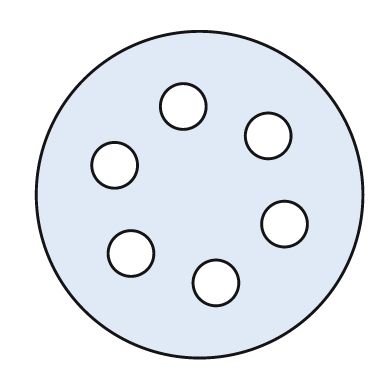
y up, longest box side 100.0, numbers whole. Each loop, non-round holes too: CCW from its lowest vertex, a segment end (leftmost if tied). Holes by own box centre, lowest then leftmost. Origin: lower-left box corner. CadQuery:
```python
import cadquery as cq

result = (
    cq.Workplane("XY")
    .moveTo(50.0, 50.0)
    .circle(50.0)
    .moveTo(55.0, 23.0)
    .circle(7.0)
    .moveTo(29.0, 32.0)
    .circle(7.0)
    .moveTo(76.0, 41.0)
    .circle(7.0)
    .moveTo(24.0, 59.0)
    .circle(7.0)
    .moveTo(71.0, 68.0)
    .circle(7.0)
    .moveTo(45.0, 77.0)
    .circle(7.0)
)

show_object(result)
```